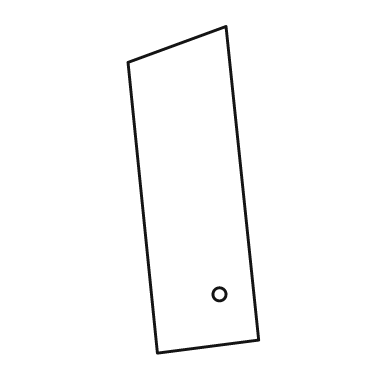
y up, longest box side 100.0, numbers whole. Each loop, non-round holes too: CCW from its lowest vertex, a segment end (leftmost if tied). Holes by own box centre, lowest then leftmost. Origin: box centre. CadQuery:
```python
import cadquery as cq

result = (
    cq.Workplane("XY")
    .moveTo(-11.0, -50.0)
    .lineTo(20.0, -46.0)
    .lineTo(10.0, 50.0)
    .lineTo(-20.0, 39.0)
    .close()
    .moveTo(8.0, -32.0)
    .circle(2.0)
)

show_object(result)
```